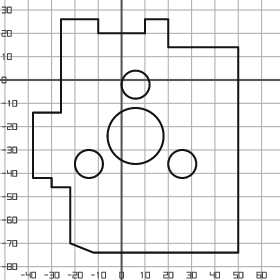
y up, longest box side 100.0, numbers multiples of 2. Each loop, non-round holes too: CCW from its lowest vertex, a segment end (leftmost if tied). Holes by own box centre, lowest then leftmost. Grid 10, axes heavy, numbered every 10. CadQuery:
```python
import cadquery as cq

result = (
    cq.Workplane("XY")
    .moveTo(-12.0, -74.0)
    .lineTo(50.0, -74.0)
    .lineTo(50.0, 14.0)
    .lineTo(20.0, 14.0)
    .lineTo(20.0, 26.0)
    .lineTo(10.0, 26.0)
    .lineTo(10.0, 20.0)
    .lineTo(-10.0, 20.0)
    .lineTo(-10.0, 26.0)
    .lineTo(-26.0, 26.0)
    .lineTo(-26.0, -14.0)
    .lineTo(-38.0, -14.0)
    .lineTo(-38.0, -42.0)
    .lineTo(-30.0, -42.0)
    .lineTo(-30.0, -46.0)
    .lineTo(-22.0, -46.0)
    .lineTo(-22.0, -70.0)
    .close()
    .moveTo(-14.0, -36.0)
    .circle(6.0)
    .moveTo(26.0, -36.0)
    .circle(6.0)
    .moveTo(6.0, -24.0)
    .circle(12.0)
    .moveTo(6.0, -2.0)
    .circle(6.0)
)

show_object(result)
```